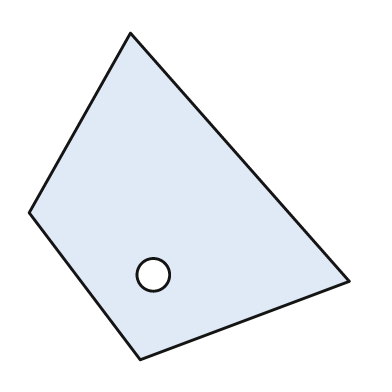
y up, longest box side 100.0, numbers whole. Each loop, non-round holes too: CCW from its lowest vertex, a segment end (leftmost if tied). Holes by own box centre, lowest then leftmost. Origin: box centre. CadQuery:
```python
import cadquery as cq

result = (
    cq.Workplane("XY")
    .moveTo(-15.0, -50.0)
    .lineTo(49.0, -26.0)
    .lineTo(-18.0, 50.0)
    .lineTo(-49.0, -5.0)
    .close()
    .moveTo(-11.0, -24.0)
    .circle(5.0)
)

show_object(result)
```